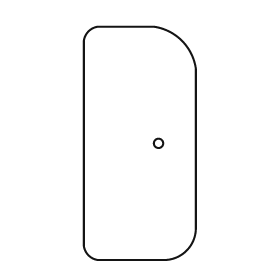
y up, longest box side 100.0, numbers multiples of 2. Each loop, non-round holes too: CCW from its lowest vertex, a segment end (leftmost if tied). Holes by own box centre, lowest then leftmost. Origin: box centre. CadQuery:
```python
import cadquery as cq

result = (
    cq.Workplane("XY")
    .moveTo(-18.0, -50.0)
    .lineTo(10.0, -50.0)
    .threePointArc((20.0, -46.0), (24.0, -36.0))
    .lineTo(24.0, 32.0)
    .threePointArc((18.0, 44.0), (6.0, 50.0))
    .lineTo(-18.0, 50.0)
    .threePointArc((-22.0, 48.0), (-24.0, 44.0))
    .lineTo(-24.0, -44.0)
    .threePointArc((-22.0, -48.0), (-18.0, -50.0))
    .close()
    .moveTo(8.0, 0.0)
    .circle(2.0)
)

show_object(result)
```